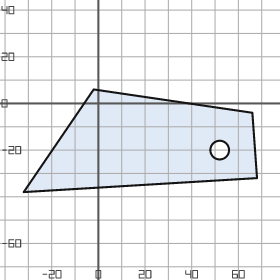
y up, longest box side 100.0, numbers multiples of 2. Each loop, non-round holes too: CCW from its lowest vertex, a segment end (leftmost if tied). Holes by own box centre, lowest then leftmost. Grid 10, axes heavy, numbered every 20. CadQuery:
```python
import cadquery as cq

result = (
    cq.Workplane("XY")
    .moveTo(-32.0, -38.0)
    .lineTo(68.0, -32.0)
    .lineTo(66.0, -4.0)
    .lineTo(-2.0, 6.0)
    .close()
    .moveTo(52.0, -20.0)
    .circle(4.0)
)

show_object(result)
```